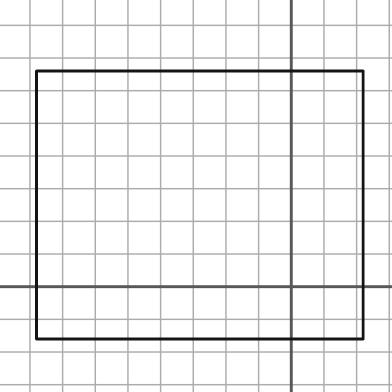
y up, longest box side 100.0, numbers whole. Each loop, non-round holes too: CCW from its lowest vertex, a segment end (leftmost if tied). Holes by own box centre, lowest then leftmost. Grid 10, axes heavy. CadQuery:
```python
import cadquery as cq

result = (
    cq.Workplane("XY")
    .moveTo(-78.0, -16.0)
    .lineTo(22.0, -16.0)
    .lineTo(22.0, 66.0)
    .lineTo(-78.0, 66.0)
    .close()
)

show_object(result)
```